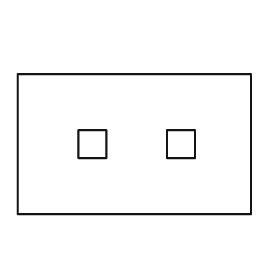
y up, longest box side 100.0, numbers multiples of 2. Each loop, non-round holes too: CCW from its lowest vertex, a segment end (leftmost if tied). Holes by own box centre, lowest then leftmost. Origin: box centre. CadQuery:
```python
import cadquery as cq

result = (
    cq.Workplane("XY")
    .moveTo(-50.0, -30.0)
    .lineTo(50.0, -30.0)
    .lineTo(50.0, 30.0)
    .lineTo(-50.0, 30.0)
    .close()
    .moveTo(-24.0, -6.0)
    .lineTo(-12.0, -6.0)
    .lineTo(-12.0, 6.0)
    .lineTo(-24.0, 6.0)
    .close()
    .moveTo(14.0, -6.0)
    .lineTo(26.0, -6.0)
    .lineTo(26.0, 6.0)
    .lineTo(14.0, 6.0)
    .close()
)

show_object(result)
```